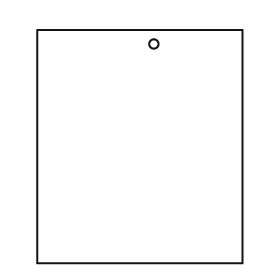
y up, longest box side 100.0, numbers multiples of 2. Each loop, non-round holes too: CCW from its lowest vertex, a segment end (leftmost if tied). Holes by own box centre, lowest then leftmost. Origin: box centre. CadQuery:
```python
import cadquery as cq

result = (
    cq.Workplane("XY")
    .moveTo(-44.0, -50.0)
    .lineTo(44.0, -50.0)
    .lineTo(44.0, 50.0)
    .lineTo(-44.0, 50.0)
    .close()
    .moveTo(6.0, 44.0)
    .circle(2.0)
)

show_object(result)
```